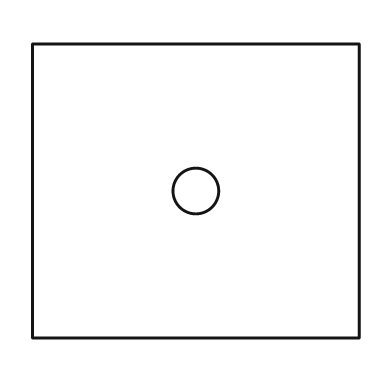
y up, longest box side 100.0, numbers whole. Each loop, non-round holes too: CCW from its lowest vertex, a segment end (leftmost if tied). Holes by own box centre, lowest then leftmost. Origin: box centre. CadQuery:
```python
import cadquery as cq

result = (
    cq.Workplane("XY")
    .moveTo(-50.0, -45.0)
    .lineTo(50.0, -45.0)
    .lineTo(50.0, 45.0)
    .lineTo(-50.0, 45.0)
    .close()
    .moveTo(0.0, 0.0)
    .circle(7.0)
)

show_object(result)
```